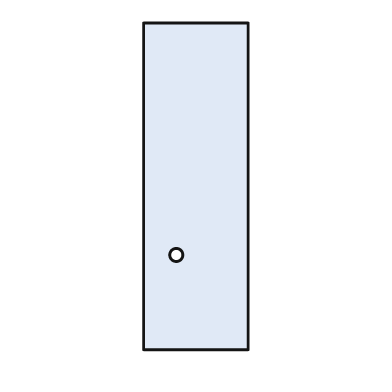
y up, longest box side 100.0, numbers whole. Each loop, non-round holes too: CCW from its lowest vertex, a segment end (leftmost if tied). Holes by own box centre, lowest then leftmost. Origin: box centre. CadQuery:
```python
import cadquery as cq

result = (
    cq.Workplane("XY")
    .moveTo(-16.0, -50.0)
    .lineTo(16.0, -50.0)
    .lineTo(16.0, 50.0)
    .lineTo(-16.0, 50.0)
    .close()
    .moveTo(-6.0, -21.0)
    .circle(2.0)
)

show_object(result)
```